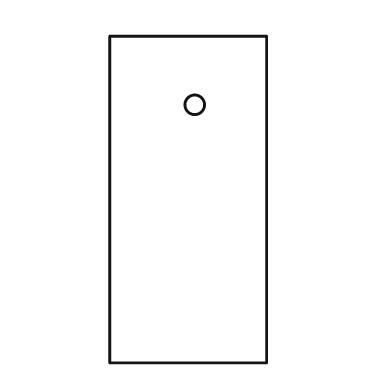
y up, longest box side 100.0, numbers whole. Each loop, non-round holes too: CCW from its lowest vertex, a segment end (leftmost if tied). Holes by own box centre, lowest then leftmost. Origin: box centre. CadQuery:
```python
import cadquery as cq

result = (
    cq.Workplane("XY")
    .moveTo(-24.0, -50.0)
    .lineTo(24.0, -50.0)
    .lineTo(24.0, 50.0)
    .lineTo(-24.0, 50.0)
    .close()
    .moveTo(2.0, 29.0)
    .circle(3.0)
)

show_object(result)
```